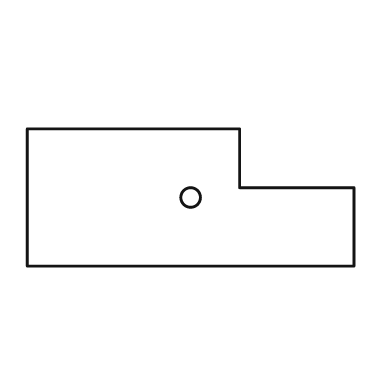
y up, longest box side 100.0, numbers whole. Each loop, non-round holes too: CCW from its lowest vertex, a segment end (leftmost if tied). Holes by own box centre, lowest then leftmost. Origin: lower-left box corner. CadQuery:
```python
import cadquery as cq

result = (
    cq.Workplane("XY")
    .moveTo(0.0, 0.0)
    .lineTo(100.0, 0.0)
    .lineTo(100.0, 24.0)
    .lineTo(65.0, 24.0)
    .lineTo(65.0, 42.0)
    .lineTo(0.0, 42.0)
    .close()
    .moveTo(50.0, 21.0)
    .circle(3.0)
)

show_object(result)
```